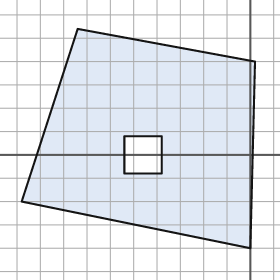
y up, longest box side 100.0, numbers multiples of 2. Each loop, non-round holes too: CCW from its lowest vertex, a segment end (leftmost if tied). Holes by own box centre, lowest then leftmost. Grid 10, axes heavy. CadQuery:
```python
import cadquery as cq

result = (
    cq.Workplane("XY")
    .moveTo(0.0, -40.0)
    .lineTo(2.0, 40.0)
    .lineTo(-74.0, 54.0)
    .lineTo(-98.0, -20.0)
    .close()
    .moveTo(-54.0, -8.0)
    .lineTo(-38.0, -8.0)
    .lineTo(-38.0, 8.0)
    .lineTo(-54.0, 8.0)
    .close()
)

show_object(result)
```